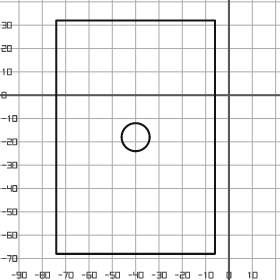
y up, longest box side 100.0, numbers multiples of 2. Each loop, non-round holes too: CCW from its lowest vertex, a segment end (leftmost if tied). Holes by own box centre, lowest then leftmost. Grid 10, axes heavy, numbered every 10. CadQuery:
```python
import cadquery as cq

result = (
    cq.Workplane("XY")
    .moveTo(-74.0, -68.0)
    .lineTo(-6.0, -68.0)
    .lineTo(-6.0, 32.0)
    .lineTo(-74.0, 32.0)
    .close()
    .moveTo(-40.0, -18.0)
    .circle(6.0)
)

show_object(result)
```